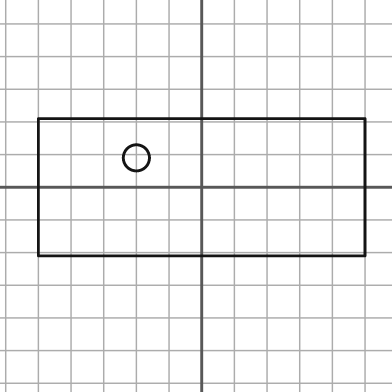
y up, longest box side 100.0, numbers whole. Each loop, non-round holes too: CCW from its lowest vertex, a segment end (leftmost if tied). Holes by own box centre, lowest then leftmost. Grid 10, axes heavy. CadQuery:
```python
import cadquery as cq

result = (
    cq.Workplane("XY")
    .moveTo(-50.0, -21.0)
    .lineTo(50.0, -21.0)
    .lineTo(50.0, 21.0)
    .lineTo(-50.0, 21.0)
    .close()
    .moveTo(-20.0, 9.0)
    .circle(4.0)
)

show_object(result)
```